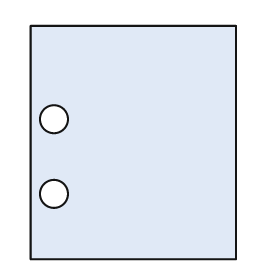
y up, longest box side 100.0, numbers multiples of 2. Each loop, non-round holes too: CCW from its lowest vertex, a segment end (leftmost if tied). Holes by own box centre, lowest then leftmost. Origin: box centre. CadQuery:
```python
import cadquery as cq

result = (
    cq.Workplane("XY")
    .moveTo(-44.0, -50.0)
    .lineTo(44.0, -50.0)
    .lineTo(44.0, 50.0)
    .lineTo(-44.0, 50.0)
    .close()
    .moveTo(-34.0, -22.0)
    .circle(6.0)
    .moveTo(-34.0, 10.0)
    .circle(6.0)
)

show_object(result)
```